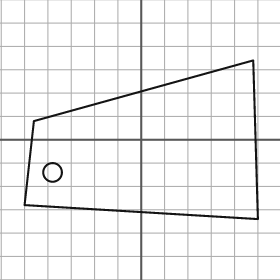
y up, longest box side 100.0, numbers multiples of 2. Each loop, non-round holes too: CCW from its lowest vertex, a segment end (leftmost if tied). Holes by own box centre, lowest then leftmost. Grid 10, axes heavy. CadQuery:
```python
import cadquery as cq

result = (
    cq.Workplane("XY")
    .moveTo(50.0, -34.0)
    .lineTo(48.0, 34.0)
    .lineTo(-46.0, 8.0)
    .lineTo(-50.0, -28.0)
    .close()
    .moveTo(-38.0, -14.0)
    .circle(4.0)
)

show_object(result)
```